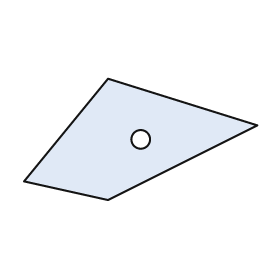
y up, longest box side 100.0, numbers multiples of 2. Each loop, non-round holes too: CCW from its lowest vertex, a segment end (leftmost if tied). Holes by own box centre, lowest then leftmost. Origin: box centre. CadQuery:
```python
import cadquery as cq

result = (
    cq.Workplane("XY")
    .moveTo(-14.0, -26.0)
    .lineTo(50.0, 6.0)
    .lineTo(-14.0, 26.0)
    .lineTo(-50.0, -18.0)
    .close()
    .moveTo(0.0, 0.0)
    .circle(4.0)
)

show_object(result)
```